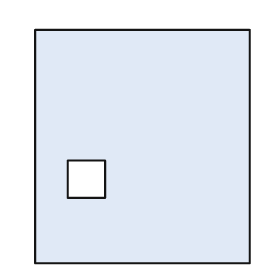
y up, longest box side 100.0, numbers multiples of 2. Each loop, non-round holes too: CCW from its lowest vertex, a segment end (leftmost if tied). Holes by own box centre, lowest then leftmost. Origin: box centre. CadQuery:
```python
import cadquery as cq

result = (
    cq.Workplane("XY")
    .moveTo(-46.0, -50.0)
    .lineTo(46.0, -50.0)
    .lineTo(46.0, 50.0)
    .lineTo(-46.0, 50.0)
    .close()
    .moveTo(-32.0, -22.0)
    .lineTo(-16.0, -22.0)
    .lineTo(-16.0, -6.0)
    .lineTo(-32.0, -6.0)
    .close()
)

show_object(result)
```